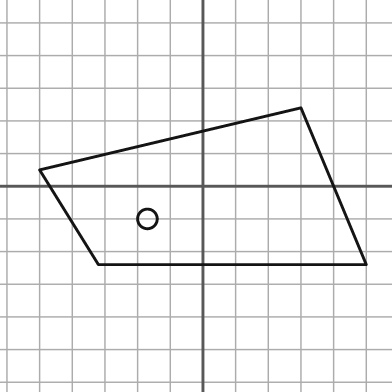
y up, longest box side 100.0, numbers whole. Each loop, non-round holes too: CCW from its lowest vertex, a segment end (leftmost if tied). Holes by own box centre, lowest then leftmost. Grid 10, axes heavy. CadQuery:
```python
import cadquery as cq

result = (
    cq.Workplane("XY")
    .moveTo(-32.0, -24.0)
    .lineTo(50.0, -24.0)
    .lineTo(30.0, 24.0)
    .lineTo(-50.0, 5.0)
    .close()
    .moveTo(-17.0, -10.0)
    .circle(3.0)
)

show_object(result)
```